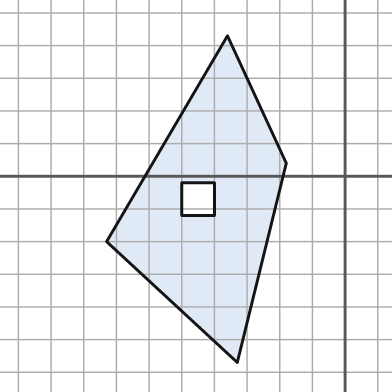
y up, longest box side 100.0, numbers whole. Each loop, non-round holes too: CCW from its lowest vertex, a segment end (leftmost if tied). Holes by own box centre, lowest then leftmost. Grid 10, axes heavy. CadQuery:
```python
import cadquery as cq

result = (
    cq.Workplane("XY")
    .moveTo(-33.0, -57.0)
    .lineTo(-18.0, 4.0)
    .lineTo(-36.0, 43.0)
    .lineTo(-73.0, -20.0)
    .close()
    .moveTo(-50.0, -12.0)
    .lineTo(-40.0, -12.0)
    .lineTo(-40.0, -2.0)
    .lineTo(-50.0, -2.0)
    .close()
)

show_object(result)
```